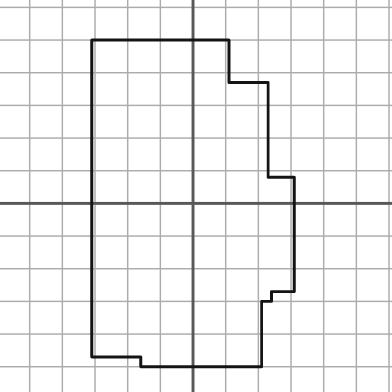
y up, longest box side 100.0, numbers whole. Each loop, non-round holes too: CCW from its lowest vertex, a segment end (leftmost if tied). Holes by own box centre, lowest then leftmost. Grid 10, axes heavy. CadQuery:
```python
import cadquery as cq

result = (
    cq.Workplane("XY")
    .moveTo(-16.0, -50.0)
    .lineTo(21.0, -50.0)
    .lineTo(21.0, -30.0)
    .lineTo(24.0, -30.0)
    .lineTo(24.0, -27.0)
    .lineTo(31.0, -27.0)
    .lineTo(31.0, 8.0)
    .lineTo(23.0, 8.0)
    .lineTo(23.0, 37.0)
    .lineTo(11.0, 37.0)
    .lineTo(11.0, 50.0)
    .lineTo(-31.0, 50.0)
    .lineTo(-31.0, -47.0)
    .lineTo(-16.0, -47.0)
    .close()
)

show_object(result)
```